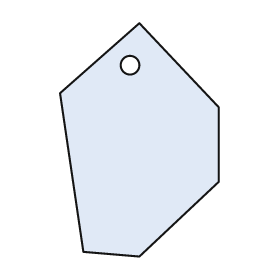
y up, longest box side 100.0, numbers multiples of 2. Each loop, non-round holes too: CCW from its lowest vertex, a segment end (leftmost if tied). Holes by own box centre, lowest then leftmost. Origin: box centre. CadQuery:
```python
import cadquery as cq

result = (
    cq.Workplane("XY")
    .moveTo(0.0, -50.0)
    .lineTo(34.0, -18.0)
    .lineTo(34.0, 14.0)
    .lineTo(0.0, 50.0)
    .lineTo(-34.0, 20.0)
    .lineTo(-24.0, -48.0)
    .close()
    .moveTo(-4.0, 32.0)
    .circle(4.0)
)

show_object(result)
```